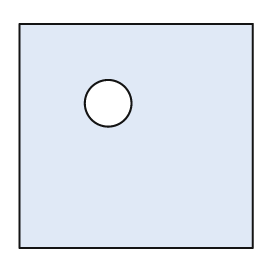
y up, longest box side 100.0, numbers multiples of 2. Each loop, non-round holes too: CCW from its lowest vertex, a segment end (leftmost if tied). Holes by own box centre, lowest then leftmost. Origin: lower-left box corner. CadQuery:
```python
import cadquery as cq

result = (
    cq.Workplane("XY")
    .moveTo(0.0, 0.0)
    .lineTo(100.0, 0.0)
    .lineTo(100.0, 96.0)
    .lineTo(0.0, 96.0)
    .close()
    .moveTo(38.0, 62.0)
    .circle(10.0)
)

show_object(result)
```